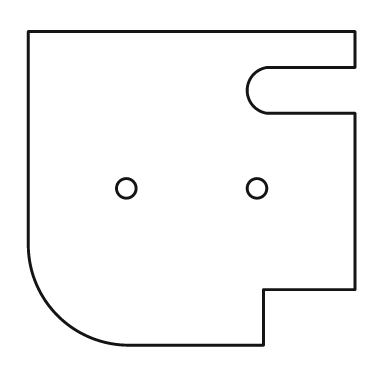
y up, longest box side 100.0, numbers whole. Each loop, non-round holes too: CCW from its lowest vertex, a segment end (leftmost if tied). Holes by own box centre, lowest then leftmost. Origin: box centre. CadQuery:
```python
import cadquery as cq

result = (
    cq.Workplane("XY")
    .moveTo(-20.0, -48.0)
    .lineTo(22.0, -48.0)
    .lineTo(22.0, -31.0)
    .lineTo(50.0, -31.0)
    .lineTo(50.0, 23.0)
    .lineTo(23.0, 23.0)
    .threePointArc((17.0, 30.0), (23.0, 37.0))
    .lineTo(50.0, 37.0)
    .lineTo(50.0, 48.0)
    .lineTo(-50.0, 48.0)
    .lineTo(-50.0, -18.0)
    .threePointArc((-41.0, -39.0), (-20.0, -48.0))
    .close()
    .moveTo(-20.0, 0.0)
    .circle(3.0)
    .moveTo(20.0, 0.0)
    .circle(3.0)
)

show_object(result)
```